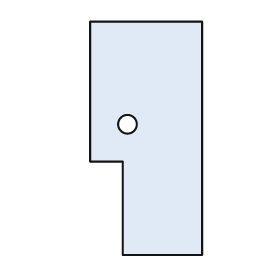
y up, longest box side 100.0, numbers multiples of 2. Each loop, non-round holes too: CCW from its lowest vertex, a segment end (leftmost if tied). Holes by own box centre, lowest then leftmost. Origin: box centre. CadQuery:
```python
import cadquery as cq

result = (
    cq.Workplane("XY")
    .moveTo(-10.0, -50.0)
    .lineTo(24.0, -50.0)
    .lineTo(24.0, 50.0)
    .lineTo(-24.0, 50.0)
    .lineTo(-24.0, -10.0)
    .lineTo(-10.0, -10.0)
    .close()
    .moveTo(-8.0, 6.0)
    .circle(4.0)
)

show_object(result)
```